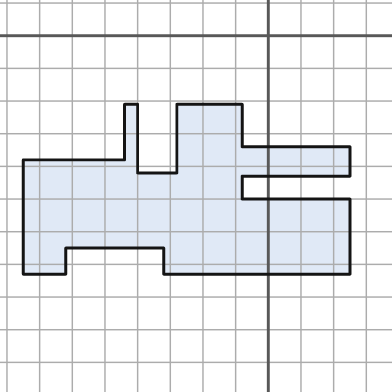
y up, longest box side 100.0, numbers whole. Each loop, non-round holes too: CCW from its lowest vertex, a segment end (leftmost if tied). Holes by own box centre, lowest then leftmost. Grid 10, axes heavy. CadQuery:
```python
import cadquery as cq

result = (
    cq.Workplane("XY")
    .moveTo(-75.0, -73.0)
    .lineTo(-62.0, -73.0)
    .lineTo(-62.0, -65.0)
    .lineTo(-32.0, -65.0)
    .lineTo(-32.0, -73.0)
    .lineTo(25.0, -73.0)
    .lineTo(25.0, -50.0)
    .lineTo(-8.0, -50.0)
    .lineTo(-8.0, -43.0)
    .lineTo(25.0, -43.0)
    .lineTo(25.0, -34.0)
    .lineTo(-8.0, -34.0)
    .lineTo(-8.0, -21.0)
    .lineTo(-28.0, -21.0)
    .lineTo(-28.0, -42.0)
    .lineTo(-40.0, -42.0)
    .lineTo(-40.0, -21.0)
    .lineTo(-44.0, -21.0)
    .lineTo(-44.0, -38.0)
    .lineTo(-75.0, -38.0)
    .close()
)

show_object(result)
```